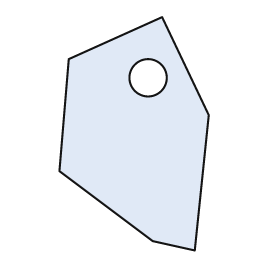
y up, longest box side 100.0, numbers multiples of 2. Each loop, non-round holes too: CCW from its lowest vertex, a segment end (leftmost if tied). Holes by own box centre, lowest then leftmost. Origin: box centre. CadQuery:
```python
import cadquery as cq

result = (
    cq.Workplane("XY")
    .moveTo(26.0, -50.0)
    .lineTo(32.0, 8.0)
    .lineTo(12.0, 50.0)
    .lineTo(-28.0, 32.0)
    .lineTo(-32.0, -16.0)
    .lineTo(8.0, -46.0)
    .close()
    .moveTo(6.0, 24.0)
    .circle(8.0)
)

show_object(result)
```